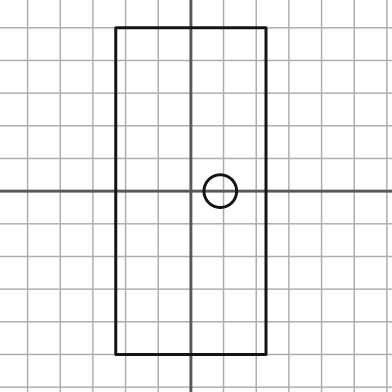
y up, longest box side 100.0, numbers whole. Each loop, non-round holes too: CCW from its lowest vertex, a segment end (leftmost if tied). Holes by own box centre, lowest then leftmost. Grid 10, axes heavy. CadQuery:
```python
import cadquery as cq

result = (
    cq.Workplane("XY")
    .moveTo(-23.0, -50.0)
    .lineTo(23.0, -50.0)
    .lineTo(23.0, 50.0)
    .lineTo(-23.0, 50.0)
    .close()
    .moveTo(9.0, 0.0)
    .circle(5.0)
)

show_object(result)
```